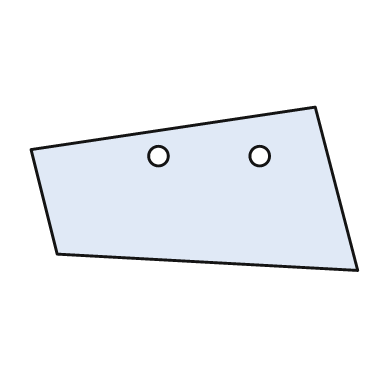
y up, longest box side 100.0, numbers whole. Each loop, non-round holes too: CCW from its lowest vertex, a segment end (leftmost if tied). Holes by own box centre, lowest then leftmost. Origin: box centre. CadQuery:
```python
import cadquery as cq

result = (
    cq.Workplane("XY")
    .moveTo(50.0, -25.0)
    .lineTo(37.0, 25.0)
    .lineTo(-50.0, 12.0)
    .lineTo(-42.0, -20.0)
    .close()
    .moveTo(-11.0, 10.0)
    .circle(3.0)
    .moveTo(20.0, 10.0)
    .circle(3.0)
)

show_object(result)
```